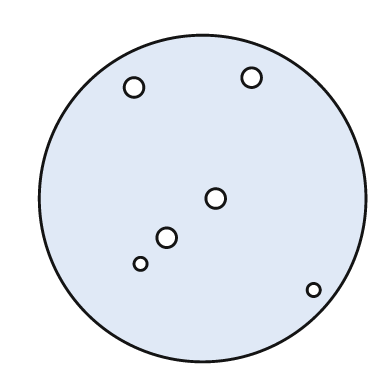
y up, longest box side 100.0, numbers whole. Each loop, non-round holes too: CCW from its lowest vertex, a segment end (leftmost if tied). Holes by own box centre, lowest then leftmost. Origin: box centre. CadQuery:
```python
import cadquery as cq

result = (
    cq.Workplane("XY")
    .moveTo(0.0, 0.0)
    .circle(50.0)
    .moveTo(34.0, -28.0)
    .circle(2.0)
    .moveTo(-19.0, -20.0)
    .circle(2.0)
    .moveTo(-11.0, -12.0)
    .circle(3.0)
    .moveTo(4.0, 0.0)
    .circle(3.0)
    .moveTo(-21.0, 34.0)
    .circle(3.0)
    .moveTo(15.0, 37.0)
    .circle(3.0)
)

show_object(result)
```